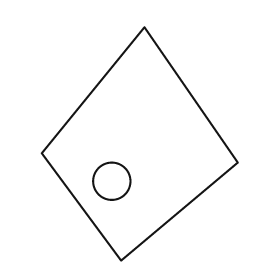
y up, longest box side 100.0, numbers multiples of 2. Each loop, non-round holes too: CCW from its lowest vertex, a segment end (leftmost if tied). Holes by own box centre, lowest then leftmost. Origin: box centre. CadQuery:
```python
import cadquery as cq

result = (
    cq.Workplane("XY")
    .moveTo(-8.0, -50.0)
    .lineTo(42.0, -8.0)
    .lineTo(2.0, 50.0)
    .lineTo(-42.0, -4.0)
    .close()
    .moveTo(-12.0, -16.0)
    .circle(8.0)
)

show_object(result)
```